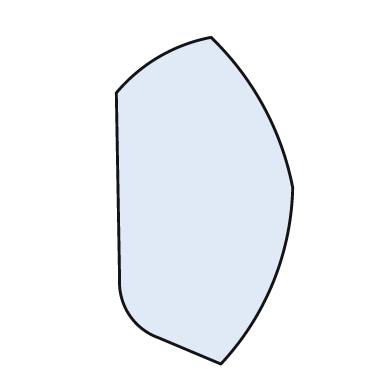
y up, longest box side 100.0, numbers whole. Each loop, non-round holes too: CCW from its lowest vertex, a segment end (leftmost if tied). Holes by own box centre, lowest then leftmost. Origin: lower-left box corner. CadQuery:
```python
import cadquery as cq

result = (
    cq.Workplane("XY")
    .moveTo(32.0, 0.0)
    .threePointArc((48.0, 25.0), (54.0, 54.0))
    .threePointArc((45.0, 79.0), (29.0, 100.0))
    .threePointArc((13.0, 94.0), (0.0, 83.0))
    .lineTo(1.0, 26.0)
    .threePointArc((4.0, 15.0), (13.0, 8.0))
    .close()
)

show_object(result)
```